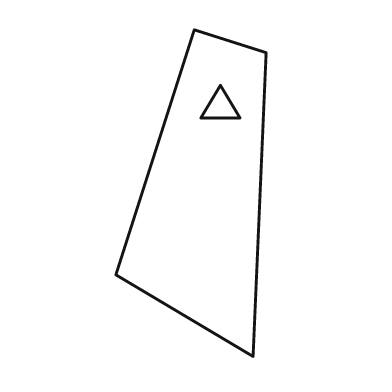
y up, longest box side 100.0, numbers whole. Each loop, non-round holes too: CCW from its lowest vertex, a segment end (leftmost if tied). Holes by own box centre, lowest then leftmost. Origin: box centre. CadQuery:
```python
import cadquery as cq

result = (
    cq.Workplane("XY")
    .moveTo(19.0, -50.0)
    .lineTo(23.0, 43.0)
    .lineTo(1.0, 50.0)
    .lineTo(-23.0, -25.0)
    .close()
    .moveTo(3.0, 23.0)
    .lineTo(15.0, 23.0)
    .lineTo(9.0, 33.0)
    .close()
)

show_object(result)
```